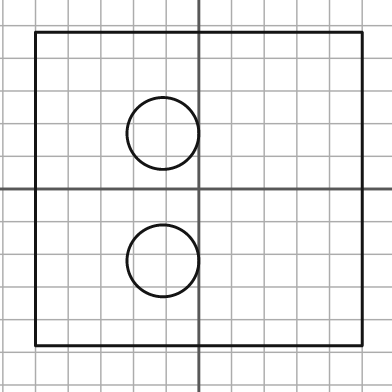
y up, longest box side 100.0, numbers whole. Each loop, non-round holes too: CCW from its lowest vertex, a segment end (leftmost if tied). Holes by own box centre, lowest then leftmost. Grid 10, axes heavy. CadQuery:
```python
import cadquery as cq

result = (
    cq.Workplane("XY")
    .moveTo(-50.0, -48.0)
    .lineTo(50.0, -48.0)
    .lineTo(50.0, 48.0)
    .lineTo(-50.0, 48.0)
    .close()
    .moveTo(-11.0, -22.0)
    .circle(11.0)
    .moveTo(-11.0, 17.0)
    .circle(11.0)
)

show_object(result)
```